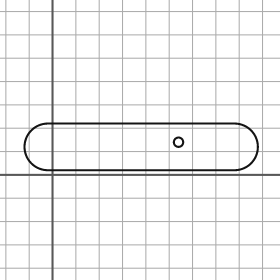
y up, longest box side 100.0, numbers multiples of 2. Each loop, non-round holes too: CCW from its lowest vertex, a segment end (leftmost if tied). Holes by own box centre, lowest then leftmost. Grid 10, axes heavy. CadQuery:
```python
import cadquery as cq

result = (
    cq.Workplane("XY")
    .moveTo(-2.0, 2.0)
    .lineTo(78.0, 2.0)
    .threePointArc((88.0, 12.0), (78.0, 22.0))
    .lineTo(-2.0, 22.0)
    .threePointArc((-12.0, 12.0), (-2.0, 2.0))
    .close()
    .moveTo(54.0, 14.0)
    .circle(2.0)
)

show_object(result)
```